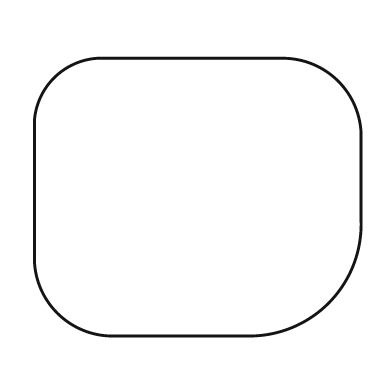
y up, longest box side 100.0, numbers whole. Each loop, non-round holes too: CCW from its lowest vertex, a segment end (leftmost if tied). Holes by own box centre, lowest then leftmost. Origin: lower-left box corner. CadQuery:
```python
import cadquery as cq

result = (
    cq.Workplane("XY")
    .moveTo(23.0, 0.0)
    .lineTo(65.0, 0.0)
    .threePointArc((90.0, 10.0), (100.0, 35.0))
    .lineTo(100.0, 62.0)
    .threePointArc((93.0, 78.0), (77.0, 85.0))
    .lineTo(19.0, 85.0)
    .threePointArc((6.0, 79.0), (0.0, 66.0))
    .lineTo(0.0, 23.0)
    .threePointArc((7.0, 7.0), (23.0, 0.0))
    .close()
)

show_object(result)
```